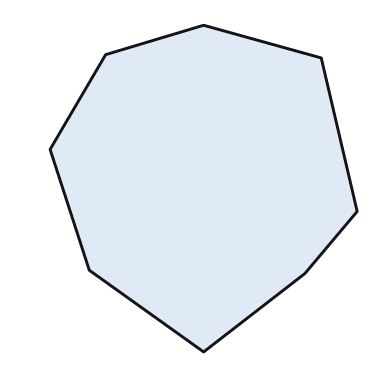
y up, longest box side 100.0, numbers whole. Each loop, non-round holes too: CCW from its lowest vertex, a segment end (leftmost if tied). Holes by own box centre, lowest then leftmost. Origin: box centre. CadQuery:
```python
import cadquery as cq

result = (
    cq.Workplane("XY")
    .moveTo(0.0, -50.0)
    .lineTo(31.0, -26.0)
    .lineTo(47.0, -7.0)
    .lineTo(36.0, 40.0)
    .lineTo(0.0, 50.0)
    .lineTo(-30.0, 41.0)
    .lineTo(-47.0, 12.0)
    .lineTo(-35.0, -25.0)
    .close()
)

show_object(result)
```